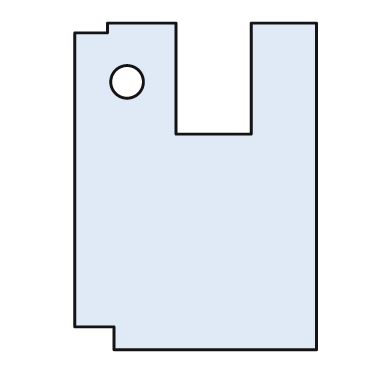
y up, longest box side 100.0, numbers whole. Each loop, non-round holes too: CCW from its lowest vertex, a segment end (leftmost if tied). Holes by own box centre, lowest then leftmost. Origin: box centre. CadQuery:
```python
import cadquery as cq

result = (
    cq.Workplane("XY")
    .moveTo(-25.0, -50.0)
    .lineTo(37.0, -50.0)
    .lineTo(37.0, 50.0)
    .lineTo(17.0, 50.0)
    .lineTo(17.0, 16.0)
    .lineTo(-6.0, 16.0)
    .lineTo(-6.0, 50.0)
    .lineTo(-27.0, 50.0)
    .lineTo(-27.0, 47.0)
    .lineTo(-37.0, 47.0)
    .lineTo(-37.0, -43.0)
    .lineTo(-25.0, -43.0)
    .close()
    .moveTo(-21.0, 32.0)
    .circle(5.0)
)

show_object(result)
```